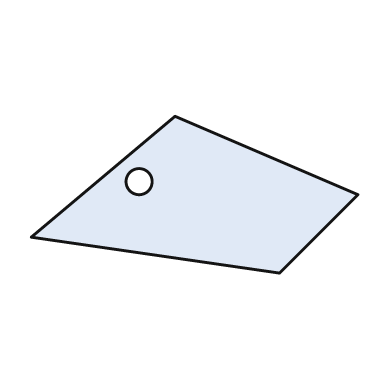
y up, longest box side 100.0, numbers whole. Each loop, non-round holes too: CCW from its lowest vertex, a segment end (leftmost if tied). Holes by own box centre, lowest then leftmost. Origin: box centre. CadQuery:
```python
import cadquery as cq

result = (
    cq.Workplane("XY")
    .moveTo(26.0, -24.0)
    .lineTo(50.0, 0.0)
    .lineTo(-6.0, 24.0)
    .lineTo(-50.0, -13.0)
    .close()
    .moveTo(-17.0, 4.0)
    .circle(4.0)
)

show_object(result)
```